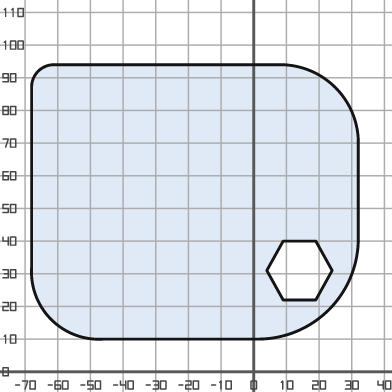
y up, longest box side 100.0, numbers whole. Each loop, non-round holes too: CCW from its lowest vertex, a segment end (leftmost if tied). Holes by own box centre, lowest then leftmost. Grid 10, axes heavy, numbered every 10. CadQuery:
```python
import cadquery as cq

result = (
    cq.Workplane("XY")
    .moveTo(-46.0, 10.0)
    .lineTo(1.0, 10.0)
    .threePointArc((23.0, 19.0), (32.0, 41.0))
    .lineTo(32.0, 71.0)
    .threePointArc((25.0, 87.0), (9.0, 94.0))
    .lineTo(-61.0, 94.0)
    .threePointArc((-66.0, 92.0), (-68.0, 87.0))
    .lineTo(-68.0, 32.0)
    .threePointArc((-62.0, 16.0), (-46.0, 10.0))
    .close()
    .moveTo(9.0, 22.0)
    .lineTo(19.0, 22.0)
    .lineTo(24.0, 31.0)
    .lineTo(19.0, 40.0)
    .lineTo(9.0, 40.0)
    .lineTo(4.0, 31.0)
    .close()
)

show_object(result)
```